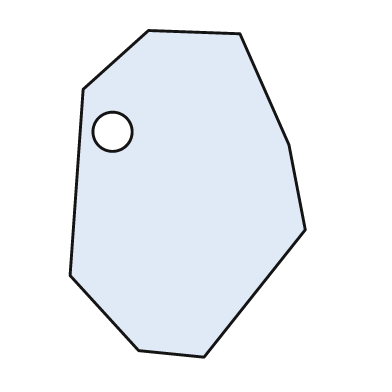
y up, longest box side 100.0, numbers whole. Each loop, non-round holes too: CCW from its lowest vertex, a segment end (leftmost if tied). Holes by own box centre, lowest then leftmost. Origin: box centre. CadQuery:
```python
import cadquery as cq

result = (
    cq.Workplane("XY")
    .moveTo(5.0, -50.0)
    .lineTo(36.0, -11.0)
    .lineTo(31.0, 15.0)
    .lineTo(16.0, 49.0)
    .lineTo(-12.0, 50.0)
    .lineTo(-32.0, 32.0)
    .lineTo(-36.0, -25.0)
    .lineTo(-15.0, -48.0)
    .close()
    .moveTo(-23.0, 19.0)
    .circle(6.0)
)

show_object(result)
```